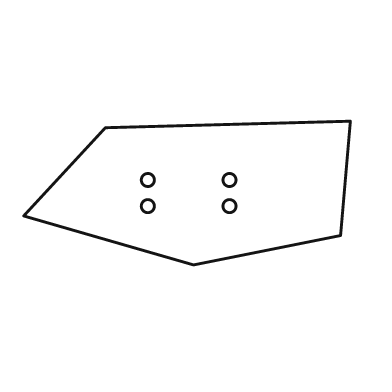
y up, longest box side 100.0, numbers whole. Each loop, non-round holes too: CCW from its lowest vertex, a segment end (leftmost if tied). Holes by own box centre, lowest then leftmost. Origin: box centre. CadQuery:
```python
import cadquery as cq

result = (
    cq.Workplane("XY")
    .moveTo(2.0, -22.0)
    .lineTo(47.0, -13.0)
    .lineTo(50.0, 22.0)
    .lineTo(-25.0, 20.0)
    .lineTo(-50.0, -7.0)
    .close()
    .moveTo(-12.0, -4.0)
    .circle(2.0)
    .moveTo(13.0, -4.0)
    .circle(2.0)
    .moveTo(-12.0, 4.0)
    .circle(2.0)
    .moveTo(13.0, 4.0)
    .circle(2.0)
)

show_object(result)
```